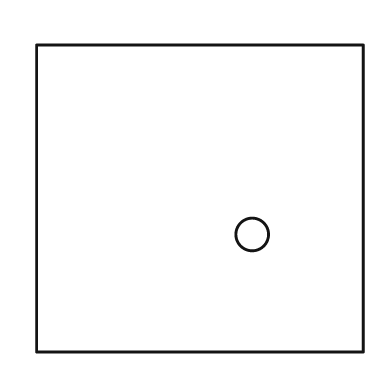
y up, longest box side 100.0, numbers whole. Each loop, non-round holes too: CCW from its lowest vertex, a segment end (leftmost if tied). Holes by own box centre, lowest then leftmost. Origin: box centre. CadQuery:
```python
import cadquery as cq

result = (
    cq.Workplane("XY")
    .moveTo(-50.0, -47.0)
    .lineTo(50.0, -47.0)
    .lineTo(50.0, 47.0)
    .lineTo(-50.0, 47.0)
    .close()
    .moveTo(16.0, -11.0)
    .circle(5.0)
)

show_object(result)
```